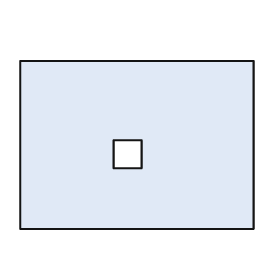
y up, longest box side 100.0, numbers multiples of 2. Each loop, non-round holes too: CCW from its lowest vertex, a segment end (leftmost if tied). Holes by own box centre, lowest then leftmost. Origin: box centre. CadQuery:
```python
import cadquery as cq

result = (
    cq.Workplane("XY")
    .moveTo(-50.0, -36.0)
    .lineTo(50.0, -36.0)
    .lineTo(50.0, 36.0)
    .lineTo(-50.0, 36.0)
    .close()
    .moveTo(-10.0, -10.0)
    .lineTo(2.0, -10.0)
    .lineTo(2.0, 2.0)
    .lineTo(-10.0, 2.0)
    .close()
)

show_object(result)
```